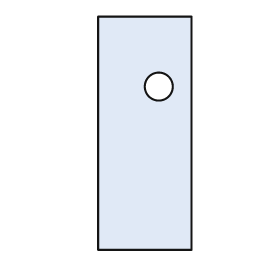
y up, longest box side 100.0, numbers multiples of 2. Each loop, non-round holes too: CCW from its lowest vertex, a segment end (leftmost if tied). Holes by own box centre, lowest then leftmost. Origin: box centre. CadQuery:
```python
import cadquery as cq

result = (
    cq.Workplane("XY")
    .moveTo(-20.0, -50.0)
    .lineTo(20.0, -50.0)
    .lineTo(20.0, 50.0)
    .lineTo(-20.0, 50.0)
    .close()
    .moveTo(6.0, 20.0)
    .circle(6.0)
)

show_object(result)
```